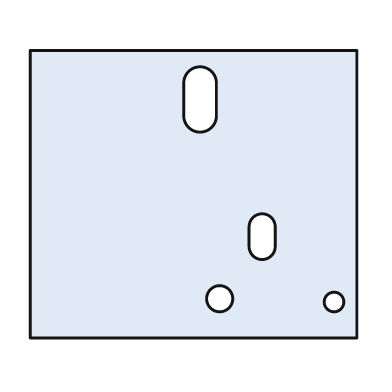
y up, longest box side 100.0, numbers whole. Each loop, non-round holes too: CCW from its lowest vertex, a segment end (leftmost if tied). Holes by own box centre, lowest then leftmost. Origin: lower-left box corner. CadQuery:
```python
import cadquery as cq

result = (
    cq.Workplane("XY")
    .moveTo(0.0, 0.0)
    .lineTo(100.0, 0.0)
    .lineTo(100.0, 88.0)
    .lineTo(0.0, 88.0)
    .close()
    .moveTo(93.0, 11.0)
    .circle(3.0)
    .moveTo(58.0, 12.0)
    .circle(4.0)
    .moveTo(67.0, 28.0)
    .threePointArc((71.0, 24.0), (75.0, 28.0))
    .lineTo(75.0, 34.0)
    .threePointArc((71.0, 38.0), (67.0, 34.0))
    .close()
    .moveTo(47.0, 68.0)
    .threePointArc((52.0, 63.0), (57.0, 68.0))
    .lineTo(57.0, 78.0)
    .threePointArc((52.0, 83.0), (47.0, 78.0))
    .close()
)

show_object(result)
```